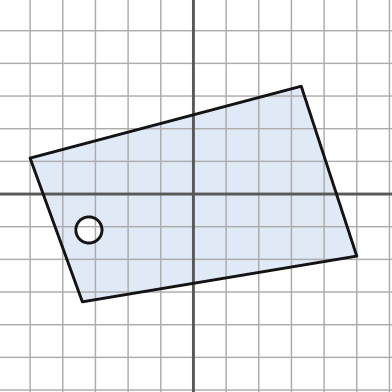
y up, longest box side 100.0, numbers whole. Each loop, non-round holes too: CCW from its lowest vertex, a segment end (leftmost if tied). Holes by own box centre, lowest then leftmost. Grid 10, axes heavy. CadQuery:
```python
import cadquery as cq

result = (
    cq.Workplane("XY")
    .moveTo(-34.0, -33.0)
    .lineTo(50.0, -19.0)
    .lineTo(33.0, 33.0)
    .lineTo(-50.0, 11.0)
    .close()
    .moveTo(-32.0, -11.0)
    .circle(4.0)
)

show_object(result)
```